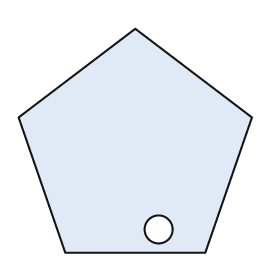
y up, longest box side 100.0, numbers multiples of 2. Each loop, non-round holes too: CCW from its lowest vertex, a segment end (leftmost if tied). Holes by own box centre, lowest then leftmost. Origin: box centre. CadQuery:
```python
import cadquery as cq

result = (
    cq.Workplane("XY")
    .moveTo(-30.0, -48.0)
    .lineTo(30.0, -48.0)
    .lineTo(50.0, 10.0)
    .lineTo(0.0, 48.0)
    .lineTo(-50.0, 10.0)
    .close()
    .moveTo(10.0, -38.0)
    .circle(6.0)
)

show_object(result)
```